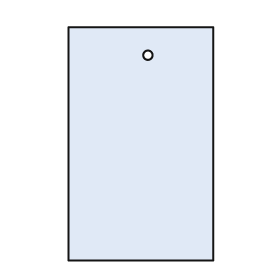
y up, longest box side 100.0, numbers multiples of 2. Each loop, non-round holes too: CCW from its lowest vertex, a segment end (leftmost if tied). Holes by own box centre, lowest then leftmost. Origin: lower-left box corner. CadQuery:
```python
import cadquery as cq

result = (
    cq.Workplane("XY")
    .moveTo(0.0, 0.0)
    .lineTo(62.0, 0.0)
    .lineTo(62.0, 100.0)
    .lineTo(0.0, 100.0)
    .close()
    .moveTo(34.0, 88.0)
    .circle(2.0)
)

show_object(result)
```